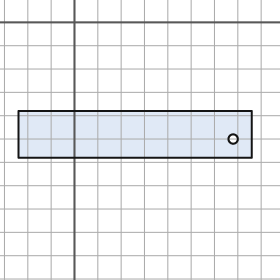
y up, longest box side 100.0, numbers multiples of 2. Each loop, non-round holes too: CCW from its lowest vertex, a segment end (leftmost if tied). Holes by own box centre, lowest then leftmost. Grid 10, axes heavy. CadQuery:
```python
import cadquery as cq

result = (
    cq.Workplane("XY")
    .moveTo(-24.0, -58.0)
    .lineTo(76.0, -58.0)
    .lineTo(76.0, -38.0)
    .lineTo(-24.0, -38.0)
    .close()
    .moveTo(68.0, -50.0)
    .circle(2.0)
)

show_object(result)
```